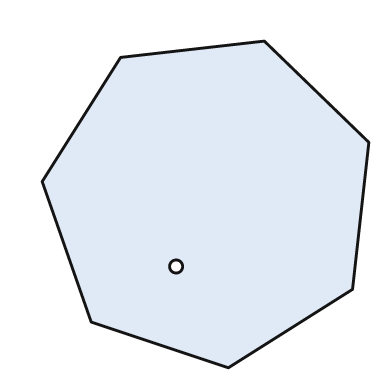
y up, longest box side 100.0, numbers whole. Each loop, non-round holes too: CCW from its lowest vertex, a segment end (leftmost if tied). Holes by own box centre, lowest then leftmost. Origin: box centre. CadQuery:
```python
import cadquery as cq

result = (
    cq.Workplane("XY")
    .moveTo(7.0, -50.0)
    .lineTo(45.0, -26.0)
    .lineTo(50.0, 19.0)
    .lineTo(18.0, 50.0)
    .lineTo(-26.0, 45.0)
    .lineTo(-50.0, 7.0)
    .lineTo(-35.0, -36.0)
    .close()
    .moveTo(-9.0, -19.0)
    .circle(2.0)
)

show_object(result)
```